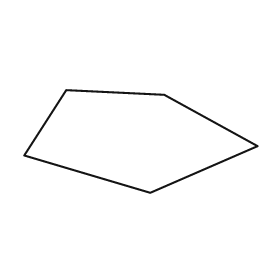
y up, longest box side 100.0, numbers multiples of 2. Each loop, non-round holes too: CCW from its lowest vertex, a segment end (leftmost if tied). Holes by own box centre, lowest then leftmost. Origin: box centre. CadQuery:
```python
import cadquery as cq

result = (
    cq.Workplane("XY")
    .moveTo(4.0, -22.0)
    .lineTo(50.0, -2.0)
    .lineTo(10.0, 20.0)
    .lineTo(-32.0, 22.0)
    .lineTo(-50.0, -6.0)
    .close()
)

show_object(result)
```